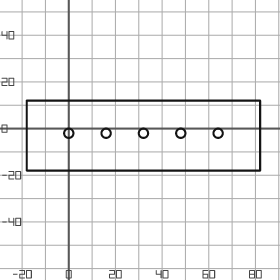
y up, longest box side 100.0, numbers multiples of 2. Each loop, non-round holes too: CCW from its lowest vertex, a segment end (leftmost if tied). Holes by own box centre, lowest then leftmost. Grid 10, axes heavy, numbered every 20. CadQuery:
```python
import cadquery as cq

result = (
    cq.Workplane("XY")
    .moveTo(-18.0, -18.0)
    .lineTo(82.0, -18.0)
    .lineTo(82.0, 12.0)
    .lineTo(-18.0, 12.0)
    .close()
    .moveTo(0.0, -2.0)
    .circle(2.0)
    .moveTo(16.0, -2.0)
    .circle(2.0)
    .moveTo(32.0, -2.0)
    .circle(2.0)
    .moveTo(48.0, -2.0)
    .circle(2.0)
    .moveTo(64.0, -2.0)
    .circle(2.0)
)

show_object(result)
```